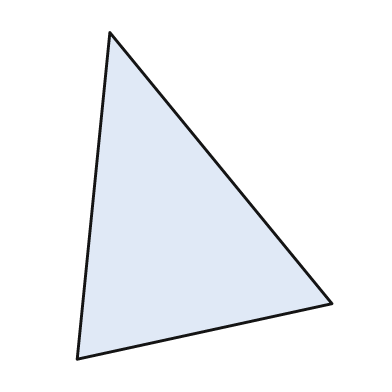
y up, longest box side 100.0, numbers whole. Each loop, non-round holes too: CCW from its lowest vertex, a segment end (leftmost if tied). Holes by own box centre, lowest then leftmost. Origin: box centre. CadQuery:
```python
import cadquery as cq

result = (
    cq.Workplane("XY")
    .moveTo(-39.0, -50.0)
    .lineTo(39.0, -33.0)
    .lineTo(-29.0, 50.0)
    .close()
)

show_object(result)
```